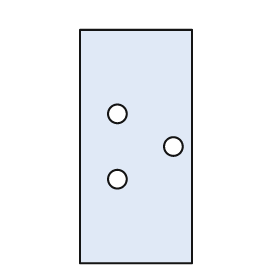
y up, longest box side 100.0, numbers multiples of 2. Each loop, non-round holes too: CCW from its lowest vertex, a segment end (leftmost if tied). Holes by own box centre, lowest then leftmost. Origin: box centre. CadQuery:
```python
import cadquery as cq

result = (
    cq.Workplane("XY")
    .moveTo(-24.0, -50.0)
    .lineTo(24.0, -50.0)
    .lineTo(24.0, 50.0)
    .lineTo(-24.0, 50.0)
    .close()
    .moveTo(-8.0, -14.0)
    .circle(4.0)
    .moveTo(16.0, 0.0)
    .circle(4.0)
    .moveTo(-8.0, 14.0)
    .circle(4.0)
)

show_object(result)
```